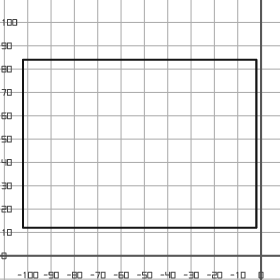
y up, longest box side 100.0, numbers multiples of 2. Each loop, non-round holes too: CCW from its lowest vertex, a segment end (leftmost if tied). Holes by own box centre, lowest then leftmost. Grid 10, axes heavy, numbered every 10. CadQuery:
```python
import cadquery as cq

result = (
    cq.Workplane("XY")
    .moveTo(-102.0, 12.0)
    .lineTo(-2.0, 12.0)
    .lineTo(-2.0, 84.0)
    .lineTo(-102.0, 84.0)
    .close()
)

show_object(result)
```